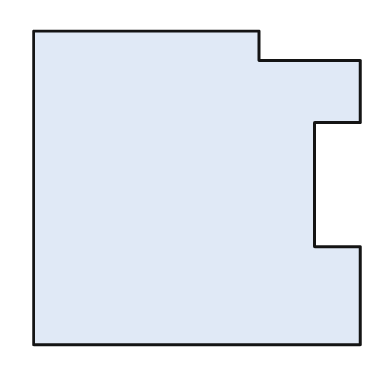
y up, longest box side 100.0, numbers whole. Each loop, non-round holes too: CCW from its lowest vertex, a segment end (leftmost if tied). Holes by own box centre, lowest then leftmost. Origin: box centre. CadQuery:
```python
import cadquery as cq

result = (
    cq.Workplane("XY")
    .moveTo(-50.0, -48.0)
    .lineTo(50.0, -48.0)
    .lineTo(50.0, -18.0)
    .lineTo(36.0, -18.0)
    .lineTo(36.0, 20.0)
    .lineTo(50.0, 20.0)
    .lineTo(50.0, 39.0)
    .lineTo(19.0, 39.0)
    .lineTo(19.0, 48.0)
    .lineTo(-50.0, 48.0)
    .close()
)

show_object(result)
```